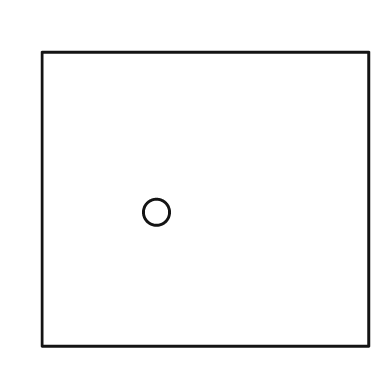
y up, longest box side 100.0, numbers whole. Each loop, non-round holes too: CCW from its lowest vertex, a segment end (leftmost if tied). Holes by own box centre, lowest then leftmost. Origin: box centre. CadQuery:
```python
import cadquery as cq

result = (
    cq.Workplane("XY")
    .moveTo(-50.0, -45.0)
    .lineTo(50.0, -45.0)
    .lineTo(50.0, 45.0)
    .lineTo(-50.0, 45.0)
    .close()
    .moveTo(-15.0, -4.0)
    .circle(4.0)
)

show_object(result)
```